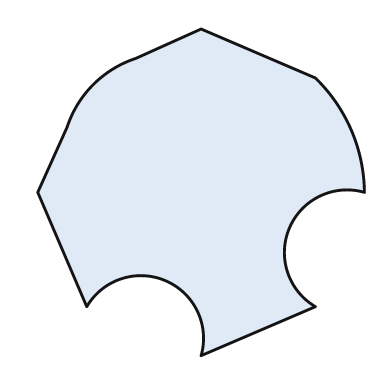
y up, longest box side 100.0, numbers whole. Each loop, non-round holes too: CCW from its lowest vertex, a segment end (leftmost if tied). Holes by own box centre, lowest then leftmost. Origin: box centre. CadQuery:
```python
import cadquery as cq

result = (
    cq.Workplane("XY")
    .moveTo(0.0, -50.0)
    .lineTo(35.0, -35.0)
    .threePointArc((27.0, -11.0), (50.0, 0.0))
    .threePointArc((46.0, 19.0), (35.0, 35.0))
    .lineTo(0.0, 50.0)
    .lineTo(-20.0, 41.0)
    .threePointArc((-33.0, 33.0), (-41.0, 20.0))
    .lineTo(-50.0, 0.0)
    .lineTo(-35.0, -35.0)
    .threePointArc((-11.0, -27.0), (0.0, -50.0))
    .close()
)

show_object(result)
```